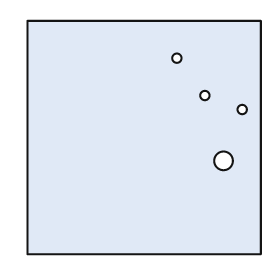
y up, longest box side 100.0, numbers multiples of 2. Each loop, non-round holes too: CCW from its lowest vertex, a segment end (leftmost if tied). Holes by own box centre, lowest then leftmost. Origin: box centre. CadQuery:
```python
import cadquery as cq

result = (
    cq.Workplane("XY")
    .moveTo(-50.0, -50.0)
    .lineTo(50.0, -50.0)
    .lineTo(50.0, 50.0)
    .lineTo(-50.0, 50.0)
    .close()
    .moveTo(34.0, -10.0)
    .circle(4.0)
    .moveTo(42.0, 12.0)
    .circle(2.0)
    .moveTo(26.0, 18.0)
    .circle(2.0)
    .moveTo(14.0, 34.0)
    .circle(2.0)
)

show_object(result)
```